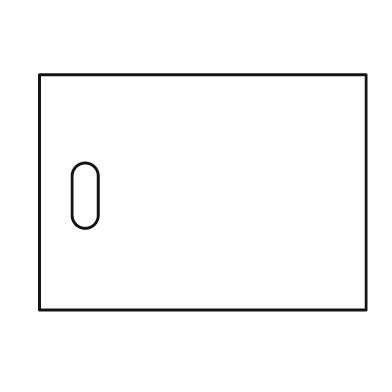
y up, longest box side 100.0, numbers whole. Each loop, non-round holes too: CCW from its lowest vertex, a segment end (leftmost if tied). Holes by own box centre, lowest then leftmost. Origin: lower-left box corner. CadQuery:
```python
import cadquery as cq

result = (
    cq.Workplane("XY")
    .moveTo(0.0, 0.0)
    .lineTo(100.0, 0.0)
    .lineTo(100.0, 72.0)
    .lineTo(0.0, 72.0)
    .close()
    .moveTo(10.0, 29.0)
    .threePointArc((14.0, 25.0), (18.0, 29.0))
    .lineTo(18.0, 41.0)
    .threePointArc((14.0, 45.0), (10.0, 41.0))
    .close()
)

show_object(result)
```